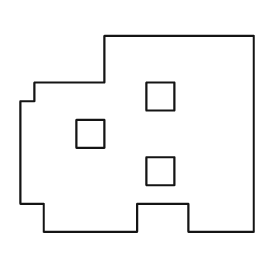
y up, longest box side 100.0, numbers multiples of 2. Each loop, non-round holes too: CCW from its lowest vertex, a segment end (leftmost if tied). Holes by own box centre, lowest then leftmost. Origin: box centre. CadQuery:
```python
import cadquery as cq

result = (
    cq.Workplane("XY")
    .moveTo(-40.0, -42.0)
    .lineTo(0.0, -42.0)
    .lineTo(0.0, -30.0)
    .lineTo(22.0, -30.0)
    .lineTo(22.0, -42.0)
    .lineTo(50.0, -42.0)
    .lineTo(50.0, 42.0)
    .lineTo(-14.0, 42.0)
    .lineTo(-14.0, 22.0)
    .lineTo(-44.0, 22.0)
    .lineTo(-44.0, 14.0)
    .lineTo(-50.0, 14.0)
    .lineTo(-50.0, -30.0)
    .lineTo(-40.0, -30.0)
    .close()
    .moveTo(4.0, -22.0)
    .lineTo(16.0, -22.0)
    .lineTo(16.0, -10.0)
    .lineTo(4.0, -10.0)
    .close()
    .moveTo(-26.0, -6.0)
    .lineTo(-14.0, -6.0)
    .lineTo(-14.0, 6.0)
    .lineTo(-26.0, 6.0)
    .close()
    .moveTo(4.0, 10.0)
    .lineTo(16.0, 10.0)
    .lineTo(16.0, 22.0)
    .lineTo(4.0, 22.0)
    .close()
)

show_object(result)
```